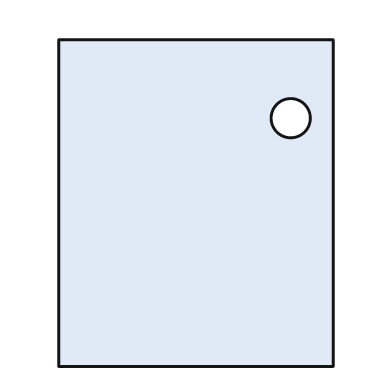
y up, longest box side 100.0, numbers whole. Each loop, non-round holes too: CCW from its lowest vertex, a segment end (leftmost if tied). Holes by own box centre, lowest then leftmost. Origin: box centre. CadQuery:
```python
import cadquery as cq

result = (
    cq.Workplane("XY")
    .moveTo(-42.0, -50.0)
    .lineTo(42.0, -50.0)
    .lineTo(42.0, 50.0)
    .lineTo(-42.0, 50.0)
    .close()
    .moveTo(29.0, 26.0)
    .circle(6.0)
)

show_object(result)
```